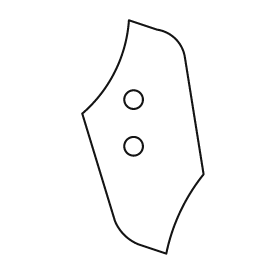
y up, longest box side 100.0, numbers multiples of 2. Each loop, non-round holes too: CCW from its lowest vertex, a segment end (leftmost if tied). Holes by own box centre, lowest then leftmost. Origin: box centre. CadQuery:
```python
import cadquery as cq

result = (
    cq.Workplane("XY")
    .moveTo(10.0, -50.0)
    .threePointArc((16.0, -32.0), (26.0, -16.0))
    .lineTo(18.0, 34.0)
    .threePointArc((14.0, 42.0), (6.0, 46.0))
    .lineTo(-6.0, 50.0)
    .threePointArc((-12.0, 28.0), (-26.0, 10.0))
    .lineTo(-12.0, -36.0)
    .threePointArc((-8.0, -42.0), (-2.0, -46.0))
    .close()
    .moveTo(-4.0, -4.0)
    .circle(4.0)
    .moveTo(-4.0, 16.0)
    .circle(4.0)
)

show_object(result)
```